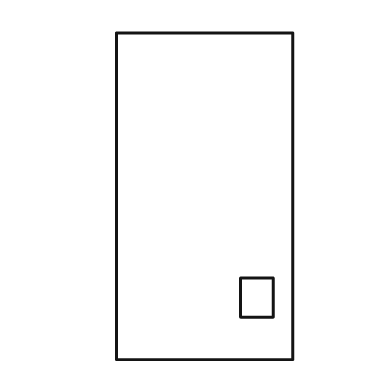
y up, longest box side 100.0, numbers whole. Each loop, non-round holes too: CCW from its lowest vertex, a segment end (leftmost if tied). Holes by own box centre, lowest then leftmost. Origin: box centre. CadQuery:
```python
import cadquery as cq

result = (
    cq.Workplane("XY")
    .moveTo(-27.0, -50.0)
    .lineTo(27.0, -50.0)
    .lineTo(27.0, 50.0)
    .lineTo(-27.0, 50.0)
    .close()
    .moveTo(11.0, -37.0)
    .lineTo(21.0, -37.0)
    .lineTo(21.0, -25.0)
    .lineTo(11.0, -25.0)
    .close()
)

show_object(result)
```